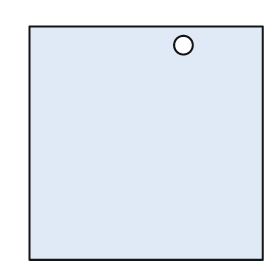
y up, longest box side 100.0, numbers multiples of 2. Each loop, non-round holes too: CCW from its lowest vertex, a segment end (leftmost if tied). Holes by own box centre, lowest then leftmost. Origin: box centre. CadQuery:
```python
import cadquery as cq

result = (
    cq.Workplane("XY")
    .moveTo(-50.0, -50.0)
    .lineTo(50.0, -50.0)
    .lineTo(50.0, 50.0)
    .lineTo(-50.0, 50.0)
    .close()
    .moveTo(16.0, 42.0)
    .circle(4.0)
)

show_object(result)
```